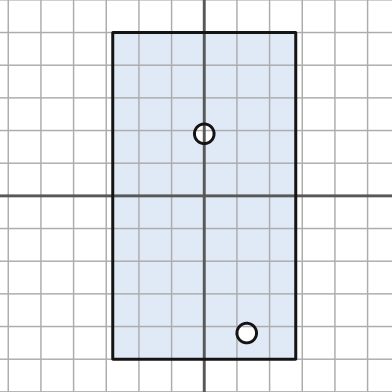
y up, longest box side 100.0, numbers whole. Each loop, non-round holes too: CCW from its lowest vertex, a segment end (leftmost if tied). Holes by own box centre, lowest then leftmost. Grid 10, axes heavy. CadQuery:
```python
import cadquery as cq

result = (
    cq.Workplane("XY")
    .moveTo(-28.0, -50.0)
    .lineTo(28.0, -50.0)
    .lineTo(28.0, 50.0)
    .lineTo(-28.0, 50.0)
    .close()
    .moveTo(13.0, -42.0)
    .circle(3.0)
    .moveTo(0.0, 19.0)
    .circle(3.0)
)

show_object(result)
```